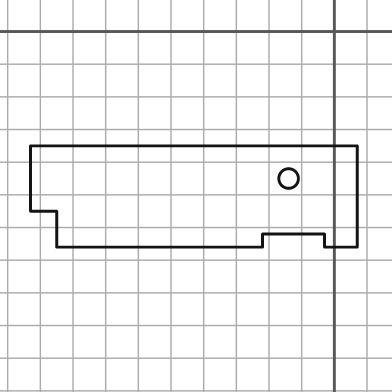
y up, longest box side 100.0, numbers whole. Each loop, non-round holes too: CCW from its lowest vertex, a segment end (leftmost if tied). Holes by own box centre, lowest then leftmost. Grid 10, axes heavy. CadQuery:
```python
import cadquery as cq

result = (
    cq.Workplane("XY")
    .moveTo(-85.0, -66.0)
    .lineTo(-22.0, -66.0)
    .lineTo(-22.0, -62.0)
    .lineTo(-3.0, -62.0)
    .lineTo(-3.0, -66.0)
    .lineTo(7.0, -66.0)
    .lineTo(7.0, -35.0)
    .lineTo(-93.0, -35.0)
    .lineTo(-93.0, -55.0)
    .lineTo(-85.0, -55.0)
    .close()
    .moveTo(-14.0, -45.0)
    .circle(3.0)
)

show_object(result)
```